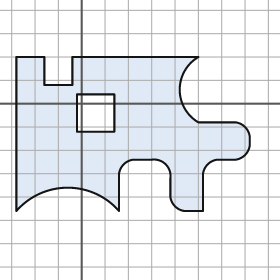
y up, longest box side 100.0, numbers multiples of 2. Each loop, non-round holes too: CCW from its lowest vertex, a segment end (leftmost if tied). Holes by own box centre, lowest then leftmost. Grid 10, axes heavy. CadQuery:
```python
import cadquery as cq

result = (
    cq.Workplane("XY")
    .moveTo(-28.0, -46.0)
    .threePointArc((-6.0, -36.0), (16.0, -46.0))
    .lineTo(16.0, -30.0)
    .threePointArc((18.0, -26.0), (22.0, -24.0))
    .lineTo(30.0, -24.0)
    .threePointArc((36.0, -26.0), (38.0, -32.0))
    .lineTo(38.0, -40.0)
    .threePointArc((40.0, -44.0), (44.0, -46.0))
    .lineTo(52.0, -46.0)
    .lineTo(52.0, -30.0)
    .threePointArc((54.0, -26.0), (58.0, -24.0))
    .lineTo(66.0, -24.0)
    .threePointArc((70.0, -22.0), (72.0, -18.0))
    .lineTo(72.0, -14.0)
    .threePointArc((70.0, -10.0), (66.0, -8.0))
    .lineTo(50.0, -8.0)
    .threePointArc((42.0, 6.0), (50.0, 20.0))
    .lineTo(-4.0, 20.0)
    .lineTo(-4.0, 8.0)
    .lineTo(-16.0, 8.0)
    .lineTo(-16.0, 20.0)
    .lineTo(-28.0, 20.0)
    .close()
    .moveTo(-2.0, -12.0)
    .lineTo(14.0, -12.0)
    .lineTo(14.0, 4.0)
    .lineTo(-2.0, 4.0)
    .close()
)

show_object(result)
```